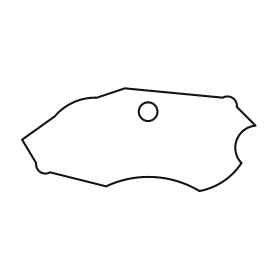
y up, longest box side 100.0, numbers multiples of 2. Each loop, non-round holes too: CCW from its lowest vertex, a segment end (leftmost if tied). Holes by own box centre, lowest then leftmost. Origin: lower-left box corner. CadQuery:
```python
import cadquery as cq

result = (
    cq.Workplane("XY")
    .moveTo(76.0, 0.0)
    .threePointArc((86.0, 4.0), (94.0, 12.0))
    .threePointArc((92.0, 22.0), (100.0, 28.0))
    .lineTo(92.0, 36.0)
    .threePointArc((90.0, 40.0), (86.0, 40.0))
    .lineTo(44.0, 44.0)
    .lineTo(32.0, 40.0)
    .threePointArc((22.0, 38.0), (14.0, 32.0))
    .lineTo(0.0, 22.0)
    .lineTo(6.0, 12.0)
    .threePointArc((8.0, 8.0), (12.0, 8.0))
    .lineTo(36.0, 2.0)
    .threePointArc((56.0, 6.0), (76.0, 0.0))
    .close()
    .moveTo(54.0, 34.0)
    .circle(4.0)
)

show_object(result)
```